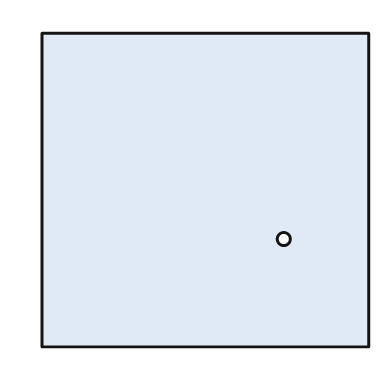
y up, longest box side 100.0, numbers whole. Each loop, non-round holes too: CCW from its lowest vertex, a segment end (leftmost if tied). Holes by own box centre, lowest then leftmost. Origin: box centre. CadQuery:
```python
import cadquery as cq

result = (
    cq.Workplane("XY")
    .moveTo(-50.0, -48.0)
    .lineTo(50.0, -48.0)
    .lineTo(50.0, 48.0)
    .lineTo(-50.0, 48.0)
    .close()
    .moveTo(24.0, -15.0)
    .circle(2.0)
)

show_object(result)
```